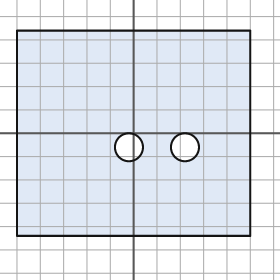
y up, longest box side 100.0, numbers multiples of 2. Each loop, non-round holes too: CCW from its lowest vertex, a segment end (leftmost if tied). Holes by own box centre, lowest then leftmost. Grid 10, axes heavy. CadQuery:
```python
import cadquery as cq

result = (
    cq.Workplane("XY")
    .moveTo(-50.0, -44.0)
    .lineTo(50.0, -44.0)
    .lineTo(50.0, 44.0)
    .lineTo(-50.0, 44.0)
    .close()
    .moveTo(-2.0, -6.0)
    .circle(6.0)
    .moveTo(22.0, -6.0)
    .circle(6.0)
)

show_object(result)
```